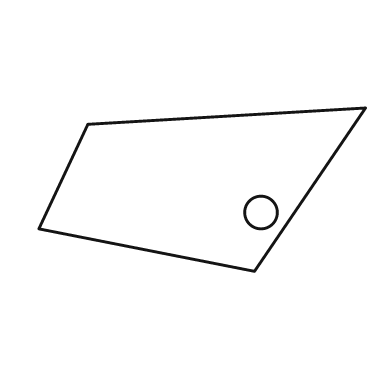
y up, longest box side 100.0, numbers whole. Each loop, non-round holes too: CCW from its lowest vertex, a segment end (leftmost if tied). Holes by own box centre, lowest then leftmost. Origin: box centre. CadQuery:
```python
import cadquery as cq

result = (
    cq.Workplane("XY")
    .moveTo(16.0, -25.0)
    .lineTo(50.0, 25.0)
    .lineTo(-35.0, 20.0)
    .lineTo(-50.0, -12.0)
    .close()
    .moveTo(18.0, -7.0)
    .circle(5.0)
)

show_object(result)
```